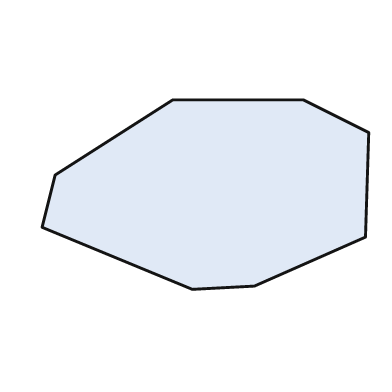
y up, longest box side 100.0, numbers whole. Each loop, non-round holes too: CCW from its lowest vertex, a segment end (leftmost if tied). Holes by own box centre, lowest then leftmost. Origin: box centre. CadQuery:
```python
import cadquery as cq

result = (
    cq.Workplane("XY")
    .moveTo(-4.0, -29.0)
    .lineTo(15.0, -28.0)
    .lineTo(49.0, -13.0)
    .lineTo(50.0, 19.0)
    .lineTo(30.0, 29.0)
    .lineTo(-10.0, 29.0)
    .lineTo(-46.0, 6.0)
    .lineTo(-50.0, -10.0)
    .close()
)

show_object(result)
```